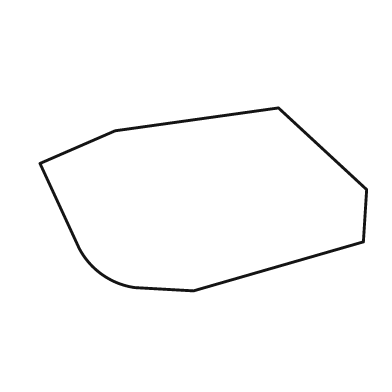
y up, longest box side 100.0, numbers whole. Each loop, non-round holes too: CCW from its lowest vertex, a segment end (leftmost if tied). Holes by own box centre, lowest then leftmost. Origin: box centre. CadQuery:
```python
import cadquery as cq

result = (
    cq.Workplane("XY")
    .moveTo(-3.0, -28.0)
    .lineTo(49.0, -13.0)
    .lineTo(50.0, 3.0)
    .lineTo(23.0, 28.0)
    .lineTo(-27.0, 21.0)
    .lineTo(-50.0, 11.0)
    .lineTo(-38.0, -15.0)
    .threePointArc((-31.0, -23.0), (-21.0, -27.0))
    .close()
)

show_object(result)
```